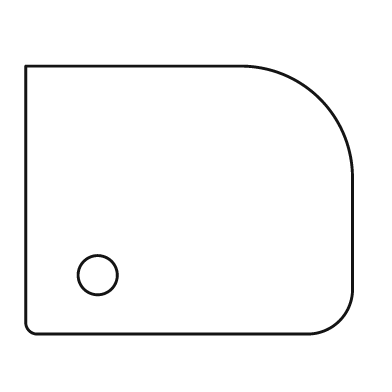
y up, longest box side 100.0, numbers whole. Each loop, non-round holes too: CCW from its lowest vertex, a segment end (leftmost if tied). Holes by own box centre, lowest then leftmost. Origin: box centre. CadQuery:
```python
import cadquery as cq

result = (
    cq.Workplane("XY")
    .moveTo(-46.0, -41.0)
    .lineTo(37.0, -41.0)
    .threePointArc((46.0, -37.0), (50.0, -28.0))
    .lineTo(50.0, 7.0)
    .threePointArc((40.0, 31.0), (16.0, 41.0))
    .lineTo(-50.0, 41.0)
    .lineTo(-50.0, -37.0)
    .threePointArc((-49.0, -40.0), (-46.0, -41.0))
    .close()
    .moveTo(-28.0, -23.0)
    .circle(6.0)
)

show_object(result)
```